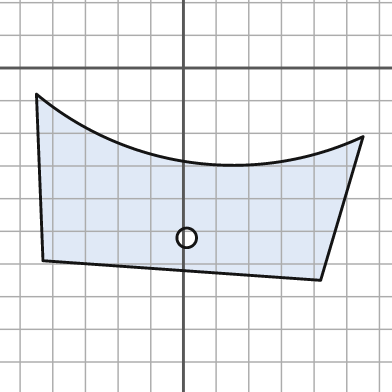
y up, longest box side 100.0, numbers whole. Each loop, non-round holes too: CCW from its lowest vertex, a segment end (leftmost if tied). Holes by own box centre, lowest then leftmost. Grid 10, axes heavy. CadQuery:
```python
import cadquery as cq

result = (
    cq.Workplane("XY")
    .moveTo(42.0, -65.0)
    .lineTo(55.0, -21.0)
    .threePointArc((3.0, -29.0), (-45.0, -8.0))
    .lineTo(-43.0, -59.0)
    .close()
    .moveTo(1.0, -52.0)
    .circle(3.0)
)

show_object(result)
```